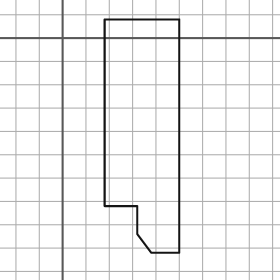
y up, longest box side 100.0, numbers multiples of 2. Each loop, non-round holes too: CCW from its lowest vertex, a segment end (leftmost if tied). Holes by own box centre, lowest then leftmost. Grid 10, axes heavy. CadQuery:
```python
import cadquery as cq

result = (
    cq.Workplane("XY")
    .moveTo(38.0, -92.0)
    .lineTo(50.0, -92.0)
    .lineTo(50.0, 8.0)
    .lineTo(18.0, 8.0)
    .lineTo(18.0, -72.0)
    .lineTo(32.0, -72.0)
    .lineTo(32.0, -84.0)
    .close()
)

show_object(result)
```